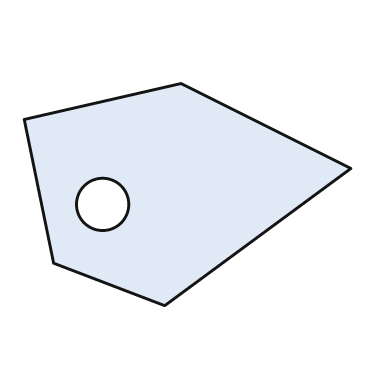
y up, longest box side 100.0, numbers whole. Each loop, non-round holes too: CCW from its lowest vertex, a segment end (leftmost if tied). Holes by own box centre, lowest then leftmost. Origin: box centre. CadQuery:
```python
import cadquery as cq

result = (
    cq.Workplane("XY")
    .moveTo(-7.0, -34.0)
    .lineTo(50.0, 8.0)
    .lineTo(-2.0, 34.0)
    .lineTo(-50.0, 23.0)
    .lineTo(-41.0, -21.0)
    .close()
    .moveTo(-26.0, -3.0)
    .circle(8.0)
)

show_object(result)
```